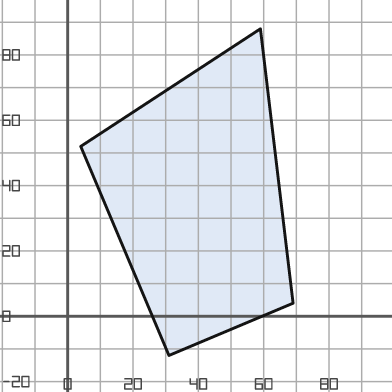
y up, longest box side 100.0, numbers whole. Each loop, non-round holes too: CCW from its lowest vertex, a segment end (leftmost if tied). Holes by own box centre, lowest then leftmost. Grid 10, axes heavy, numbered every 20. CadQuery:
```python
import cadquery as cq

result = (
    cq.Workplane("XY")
    .moveTo(31.0, -12.0)
    .lineTo(69.0, 4.0)
    .lineTo(59.0, 88.0)
    .lineTo(4.0, 52.0)
    .close()
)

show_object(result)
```